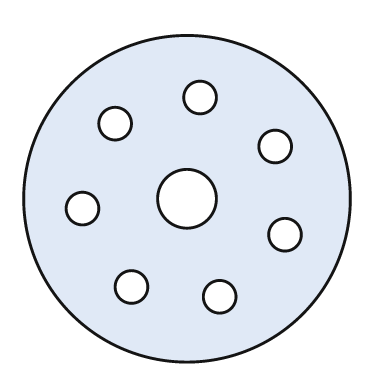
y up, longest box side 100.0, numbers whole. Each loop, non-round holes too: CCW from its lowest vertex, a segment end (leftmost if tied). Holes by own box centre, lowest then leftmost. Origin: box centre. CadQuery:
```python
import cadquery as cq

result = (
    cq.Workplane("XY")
    .moveTo(0.0, 0.0)
    .circle(50.0)
    .moveTo(10.0, -30.0)
    .circle(5.0)
    .moveTo(-17.0, -27.0)
    .circle(5.0)
    .moveTo(30.0, -11.0)
    .circle(5.0)
    .moveTo(-32.0, -3.0)
    .circle(5.0)
    .moveTo(0.0, 0.0)
    .circle(9.0)
    .moveTo(27.0, 16.0)
    .circle(5.0)
    .moveTo(-22.0, 23.0)
    .circle(5.0)
    .moveTo(4.0, 31.0)
    .circle(5.0)
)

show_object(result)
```